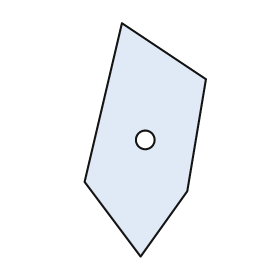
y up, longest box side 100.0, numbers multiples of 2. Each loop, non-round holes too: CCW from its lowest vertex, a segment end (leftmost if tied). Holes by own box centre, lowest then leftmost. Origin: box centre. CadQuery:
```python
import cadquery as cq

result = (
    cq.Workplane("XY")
    .moveTo(-2.0, -50.0)
    .lineTo(18.0, -22.0)
    .lineTo(26.0, 26.0)
    .lineTo(-10.0, 50.0)
    .lineTo(-26.0, -18.0)
    .close()
    .moveTo(0.0, 0.0)
    .circle(4.0)
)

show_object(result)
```